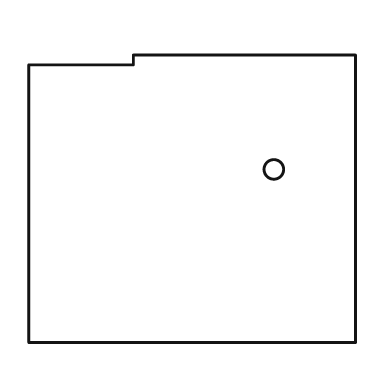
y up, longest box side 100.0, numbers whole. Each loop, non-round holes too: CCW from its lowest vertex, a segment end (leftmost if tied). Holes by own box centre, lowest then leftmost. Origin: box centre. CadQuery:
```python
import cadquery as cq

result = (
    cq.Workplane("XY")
    .moveTo(-50.0, -44.0)
    .lineTo(50.0, -44.0)
    .lineTo(50.0, 44.0)
    .lineTo(-18.0, 44.0)
    .lineTo(-18.0, 41.0)
    .lineTo(-50.0, 41.0)
    .close()
    .moveTo(25.0, 9.0)
    .circle(3.0)
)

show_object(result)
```